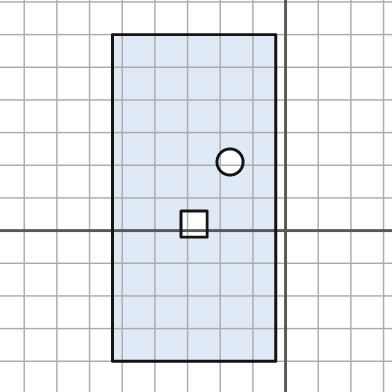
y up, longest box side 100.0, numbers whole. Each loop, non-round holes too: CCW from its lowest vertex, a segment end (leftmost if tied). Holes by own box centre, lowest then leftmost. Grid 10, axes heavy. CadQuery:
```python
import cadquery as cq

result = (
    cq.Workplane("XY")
    .moveTo(-53.0, -40.0)
    .lineTo(-3.0, -40.0)
    .lineTo(-3.0, 60.0)
    .lineTo(-53.0, 60.0)
    .close()
    .moveTo(-32.0, -2.0)
    .lineTo(-24.0, -2.0)
    .lineTo(-24.0, 6.0)
    .lineTo(-32.0, 6.0)
    .close()
    .moveTo(-17.0, 21.0)
    .circle(4.0)
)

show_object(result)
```